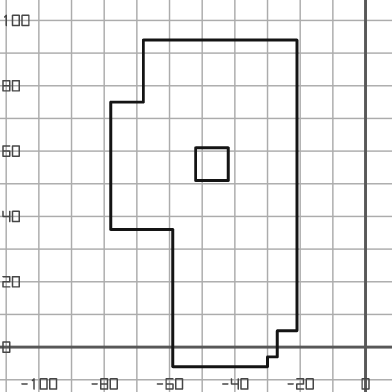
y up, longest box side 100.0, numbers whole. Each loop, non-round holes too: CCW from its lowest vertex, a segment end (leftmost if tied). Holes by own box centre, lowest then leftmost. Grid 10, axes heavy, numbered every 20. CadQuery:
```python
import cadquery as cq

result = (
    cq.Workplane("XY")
    .moveTo(-59.0, -6.0)
    .lineTo(-30.0, -6.0)
    .lineTo(-30.0, -3.0)
    .lineTo(-27.0, -3.0)
    .lineTo(-27.0, 5.0)
    .lineTo(-21.0, 5.0)
    .lineTo(-21.0, 94.0)
    .lineTo(-68.0, 94.0)
    .lineTo(-68.0, 75.0)
    .lineTo(-78.0, 75.0)
    .lineTo(-78.0, 36.0)
    .lineTo(-59.0, 36.0)
    .close()
    .moveTo(-52.0, 51.0)
    .lineTo(-42.0, 51.0)
    .lineTo(-42.0, 61.0)
    .lineTo(-52.0, 61.0)
    .close()
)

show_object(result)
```